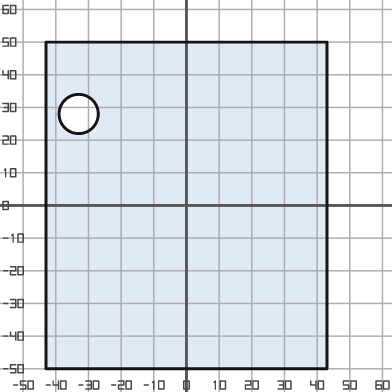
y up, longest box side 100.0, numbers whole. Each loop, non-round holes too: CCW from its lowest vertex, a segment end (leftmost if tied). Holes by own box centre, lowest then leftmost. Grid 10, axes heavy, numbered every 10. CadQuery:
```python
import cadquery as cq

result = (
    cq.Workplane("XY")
    .moveTo(-43.0, -50.0)
    .lineTo(43.0, -50.0)
    .lineTo(43.0, 50.0)
    .lineTo(-43.0, 50.0)
    .close()
    .moveTo(-33.0, 28.0)
    .circle(6.0)
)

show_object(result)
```